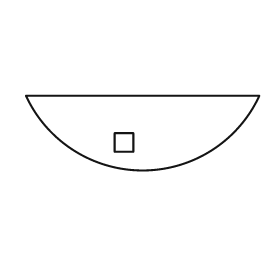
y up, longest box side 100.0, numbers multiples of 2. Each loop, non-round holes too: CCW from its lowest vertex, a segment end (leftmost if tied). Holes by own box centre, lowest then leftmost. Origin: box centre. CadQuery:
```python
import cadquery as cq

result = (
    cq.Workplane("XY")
    .moveTo(-50.0, 16.0)
    .threePointArc((0.0, -16.0), (50.0, 16.0))
    .close()
    .moveTo(-12.0, -8.0)
    .lineTo(-4.0, -8.0)
    .lineTo(-4.0, 0.0)
    .lineTo(-12.0, 0.0)
    .close()
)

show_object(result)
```